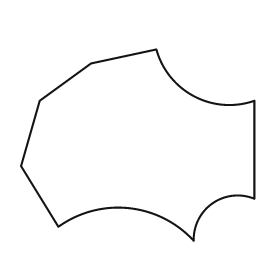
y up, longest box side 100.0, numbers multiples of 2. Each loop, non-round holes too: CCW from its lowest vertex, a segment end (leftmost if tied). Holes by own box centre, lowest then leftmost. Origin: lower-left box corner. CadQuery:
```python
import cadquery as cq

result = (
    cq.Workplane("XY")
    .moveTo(74.0, 0.0)
    .threePointArc((82.0, 16.0), (100.0, 18.0))
    .lineTo(100.0, 60.0)
    .threePointArc((74.0, 62.0), (58.0, 82.0))
    .lineTo(30.0, 76.0)
    .lineTo(8.0, 60.0)
    .lineTo(0.0, 32.0)
    .lineTo(16.0, 6.0)
    .threePointArc((46.0, 14.0), (74.0, 0.0))
    .close()
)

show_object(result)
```